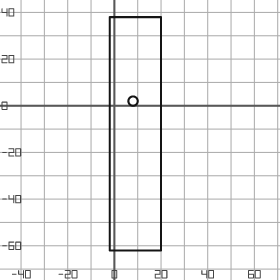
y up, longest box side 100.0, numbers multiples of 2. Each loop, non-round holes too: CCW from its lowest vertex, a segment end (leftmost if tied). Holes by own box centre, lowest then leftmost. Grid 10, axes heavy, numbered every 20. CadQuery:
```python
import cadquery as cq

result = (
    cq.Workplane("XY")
    .moveTo(-2.0, -62.0)
    .lineTo(20.0, -62.0)
    .lineTo(20.0, 38.0)
    .lineTo(-2.0, 38.0)
    .close()
    .moveTo(8.0, 2.0)
    .circle(2.0)
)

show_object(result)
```